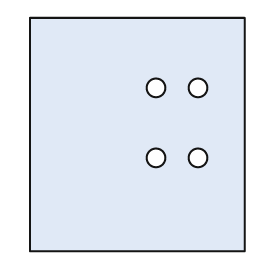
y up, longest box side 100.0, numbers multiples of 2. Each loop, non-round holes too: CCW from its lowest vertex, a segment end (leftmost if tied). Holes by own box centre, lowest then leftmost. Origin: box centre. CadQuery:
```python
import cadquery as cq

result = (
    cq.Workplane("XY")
    .moveTo(-46.0, -50.0)
    .lineTo(46.0, -50.0)
    .lineTo(46.0, 50.0)
    .lineTo(-46.0, 50.0)
    .close()
    .moveTo(8.0, -10.0)
    .circle(4.0)
    .moveTo(26.0, -10.0)
    .circle(4.0)
    .moveTo(8.0, 20.0)
    .circle(4.0)
    .moveTo(26.0, 20.0)
    .circle(4.0)
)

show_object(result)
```